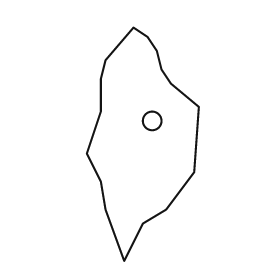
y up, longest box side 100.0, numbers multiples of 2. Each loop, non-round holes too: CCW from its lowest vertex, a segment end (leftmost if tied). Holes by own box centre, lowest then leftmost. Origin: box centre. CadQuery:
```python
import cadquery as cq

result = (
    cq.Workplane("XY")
    .moveTo(-8.0, -50.0)
    .lineTo(0.0, -34.0)
    .lineTo(10.0, -28.0)
    .lineTo(22.0, -12.0)
    .lineTo(24.0, 16.0)
    .lineTo(12.0, 26.0)
    .lineTo(8.0, 32.0)
    .lineTo(6.0, 40.0)
    .lineTo(2.0, 46.0)
    .lineTo(-4.0, 50.0)
    .lineTo(-16.0, 36.0)
    .lineTo(-18.0, 28.0)
    .lineTo(-18.0, 14.0)
    .lineTo(-24.0, -4.0)
    .lineTo(-18.0, -16.0)
    .lineTo(-16.0, -28.0)
    .close()
    .moveTo(4.0, 10.0)
    .circle(4.0)
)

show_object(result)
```